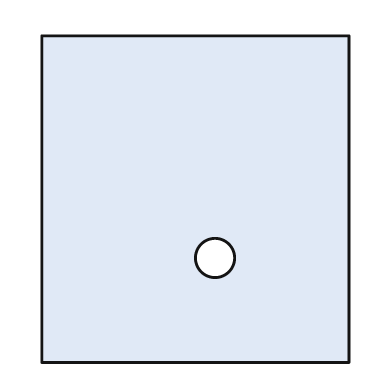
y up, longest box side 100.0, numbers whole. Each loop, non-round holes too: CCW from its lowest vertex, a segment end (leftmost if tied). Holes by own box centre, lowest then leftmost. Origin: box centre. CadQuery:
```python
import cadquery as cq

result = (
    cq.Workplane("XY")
    .moveTo(-47.0, -50.0)
    .lineTo(47.0, -50.0)
    .lineTo(47.0, 50.0)
    .lineTo(-47.0, 50.0)
    .close()
    .moveTo(6.0, -18.0)
    .circle(6.0)
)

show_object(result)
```